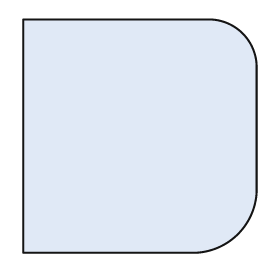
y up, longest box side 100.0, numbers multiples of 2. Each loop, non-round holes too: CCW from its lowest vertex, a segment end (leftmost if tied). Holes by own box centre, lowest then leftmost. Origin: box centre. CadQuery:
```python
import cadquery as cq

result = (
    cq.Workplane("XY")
    .moveTo(-50.0, -50.0)
    .lineTo(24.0, -50.0)
    .threePointArc((42.0, -42.0), (50.0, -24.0))
    .lineTo(50.0, 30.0)
    .threePointArc((44.0, 44.0), (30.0, 50.0))
    .lineTo(-50.0, 50.0)
    .close()
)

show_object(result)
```